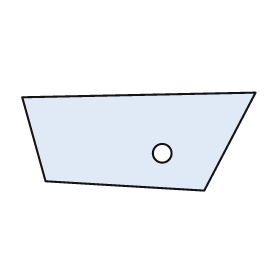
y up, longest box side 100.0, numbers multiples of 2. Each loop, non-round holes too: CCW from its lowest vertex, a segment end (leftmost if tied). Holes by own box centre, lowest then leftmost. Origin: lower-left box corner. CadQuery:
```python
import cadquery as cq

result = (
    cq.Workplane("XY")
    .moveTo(78.0, 0.0)
    .lineTo(100.0, 42.0)
    .lineTo(0.0, 40.0)
    .lineTo(10.0, 4.0)
    .close()
    .moveTo(60.0, 16.0)
    .circle(4.0)
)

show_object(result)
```